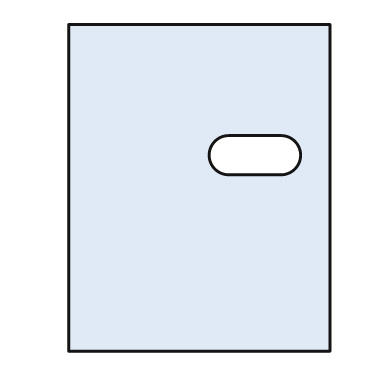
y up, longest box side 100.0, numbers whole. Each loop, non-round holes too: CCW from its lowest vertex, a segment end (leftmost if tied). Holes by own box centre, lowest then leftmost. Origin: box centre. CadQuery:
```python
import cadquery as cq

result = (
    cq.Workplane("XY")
    .moveTo(-40.0, -50.0)
    .lineTo(40.0, -50.0)
    .lineTo(40.0, 50.0)
    .lineTo(-40.0, 50.0)
    .close()
    .moveTo(9.0, 4.0)
    .lineTo(25.0, 4.0)
    .threePointArc((31.0, 10.0), (25.0, 16.0))
    .lineTo(9.0, 16.0)
    .threePointArc((3.0, 10.0), (9.0, 4.0))
    .close()
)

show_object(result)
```